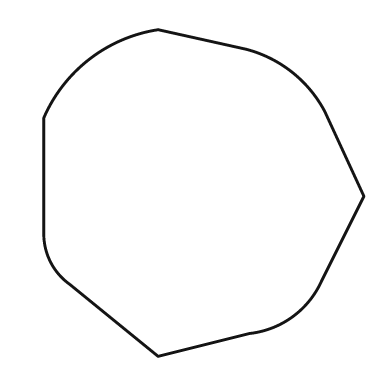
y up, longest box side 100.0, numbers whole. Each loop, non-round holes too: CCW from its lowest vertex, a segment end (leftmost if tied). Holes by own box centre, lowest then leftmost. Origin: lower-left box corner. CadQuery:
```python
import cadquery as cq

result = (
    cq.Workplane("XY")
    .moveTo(35.0, 0.0)
    .lineTo(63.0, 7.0)
    .threePointArc((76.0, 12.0), (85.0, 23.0))
    .lineTo(98.0, 49.0)
    .lineTo(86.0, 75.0)
    .threePointArc((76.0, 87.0), (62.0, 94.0))
    .lineTo(35.0, 100.0)
    .threePointArc((14.0, 91.0), (0.0, 73.0))
    .lineTo(0.0, 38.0)
    .threePointArc((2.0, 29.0), (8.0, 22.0))
    .close()
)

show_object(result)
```